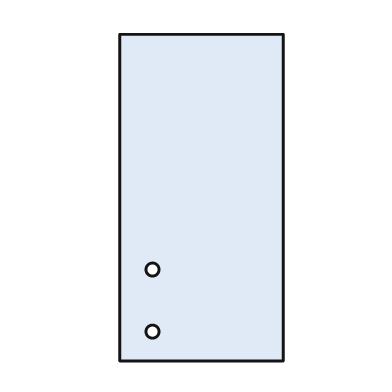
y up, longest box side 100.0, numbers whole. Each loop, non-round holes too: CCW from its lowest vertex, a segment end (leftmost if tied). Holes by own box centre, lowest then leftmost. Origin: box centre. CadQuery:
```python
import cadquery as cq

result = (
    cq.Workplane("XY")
    .moveTo(-25.0, -50.0)
    .lineTo(25.0, -50.0)
    .lineTo(25.0, 50.0)
    .lineTo(-25.0, 50.0)
    .close()
    .moveTo(-15.0, -41.0)
    .circle(2.0)
    .moveTo(-15.0, -22.0)
    .circle(2.0)
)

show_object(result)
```